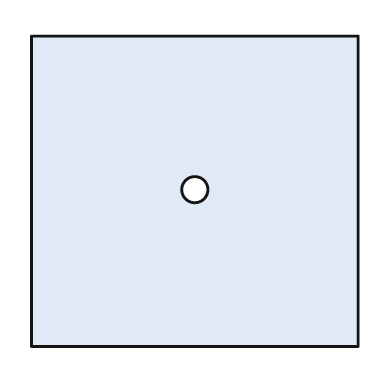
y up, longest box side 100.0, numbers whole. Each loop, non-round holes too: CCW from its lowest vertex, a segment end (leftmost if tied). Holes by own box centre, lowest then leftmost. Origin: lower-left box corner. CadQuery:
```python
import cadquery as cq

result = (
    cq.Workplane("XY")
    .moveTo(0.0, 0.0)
    .lineTo(100.0, 0.0)
    .lineTo(100.0, 95.0)
    .lineTo(0.0, 95.0)
    .close()
    .moveTo(50.0, 48.0)
    .circle(4.0)
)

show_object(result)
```